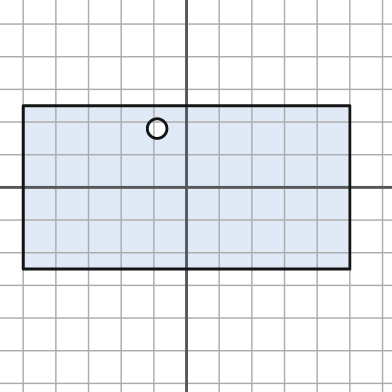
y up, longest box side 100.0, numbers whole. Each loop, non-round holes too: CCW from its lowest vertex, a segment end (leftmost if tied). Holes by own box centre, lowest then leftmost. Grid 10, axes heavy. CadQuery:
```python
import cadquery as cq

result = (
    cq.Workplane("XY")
    .moveTo(-50.0, -25.0)
    .lineTo(50.0, -25.0)
    .lineTo(50.0, 25.0)
    .lineTo(-50.0, 25.0)
    .close()
    .moveTo(-9.0, 18.0)
    .circle(3.0)
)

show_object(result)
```